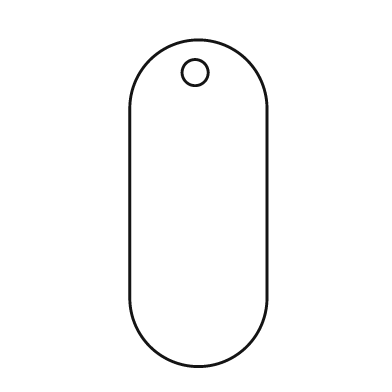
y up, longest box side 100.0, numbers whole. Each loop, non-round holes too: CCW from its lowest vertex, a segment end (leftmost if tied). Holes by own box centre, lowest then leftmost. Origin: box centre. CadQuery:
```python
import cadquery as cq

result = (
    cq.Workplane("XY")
    .moveTo(-21.0, -29.0)
    .threePointArc((0.0, -50.0), (21.0, -29.0))
    .lineTo(21.0, 29.0)
    .threePointArc((0.0, 50.0), (-21.0, 29.0))
    .close()
    .moveTo(-1.0, 40.0)
    .circle(4.0)
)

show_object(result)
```